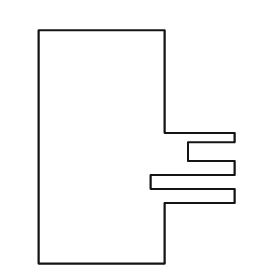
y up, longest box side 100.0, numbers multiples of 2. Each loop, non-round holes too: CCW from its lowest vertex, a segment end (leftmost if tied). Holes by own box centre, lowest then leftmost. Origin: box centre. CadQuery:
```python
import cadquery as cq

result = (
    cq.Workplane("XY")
    .moveTo(-42.0, -50.0)
    .lineTo(12.0, -50.0)
    .lineTo(12.0, -24.0)
    .lineTo(42.0, -24.0)
    .lineTo(42.0, -18.0)
    .lineTo(6.0, -18.0)
    .lineTo(6.0, -12.0)
    .lineTo(42.0, -12.0)
    .lineTo(42.0, -6.0)
    .lineTo(22.0, -6.0)
    .lineTo(22.0, 2.0)
    .lineTo(42.0, 2.0)
    .lineTo(42.0, 6.0)
    .lineTo(12.0, 6.0)
    .lineTo(12.0, 50.0)
    .lineTo(-42.0, 50.0)
    .close()
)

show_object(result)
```